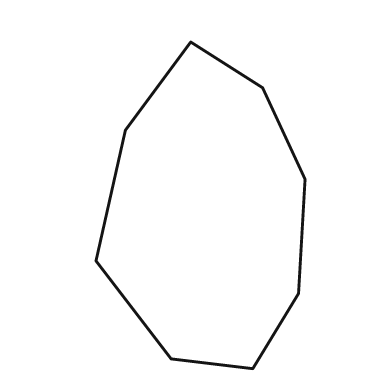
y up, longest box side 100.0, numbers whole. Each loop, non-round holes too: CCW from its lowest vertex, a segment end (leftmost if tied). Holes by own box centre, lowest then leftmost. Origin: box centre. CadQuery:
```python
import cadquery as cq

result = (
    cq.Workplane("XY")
    .moveTo(16.0, -50.0)
    .lineTo(30.0, -27.0)
    .lineTo(32.0, 8.0)
    .lineTo(19.0, 36.0)
    .lineTo(-3.0, 50.0)
    .lineTo(-23.0, 23.0)
    .lineTo(-32.0, -17.0)
    .lineTo(-9.0, -47.0)
    .close()
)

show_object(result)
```